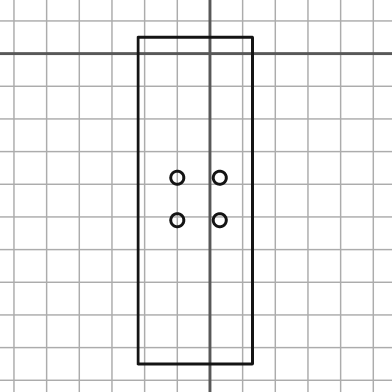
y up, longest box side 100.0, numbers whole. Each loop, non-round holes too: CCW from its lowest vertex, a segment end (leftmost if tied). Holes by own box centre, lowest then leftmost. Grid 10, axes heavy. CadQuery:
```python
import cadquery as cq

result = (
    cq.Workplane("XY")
    .moveTo(-22.0, -95.0)
    .lineTo(13.0, -95.0)
    .lineTo(13.0, 5.0)
    .lineTo(-22.0, 5.0)
    .close()
    .moveTo(-10.0, -51.0)
    .circle(2.0)
    .moveTo(3.0, -51.0)
    .circle(2.0)
    .moveTo(-10.0, -38.0)
    .circle(2.0)
    .moveTo(3.0, -38.0)
    .circle(2.0)
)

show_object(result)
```